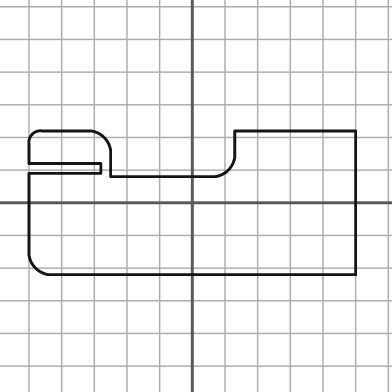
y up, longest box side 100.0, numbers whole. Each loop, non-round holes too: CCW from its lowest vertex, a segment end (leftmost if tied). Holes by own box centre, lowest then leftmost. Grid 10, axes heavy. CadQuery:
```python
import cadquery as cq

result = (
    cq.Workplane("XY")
    .moveTo(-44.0, -22.0)
    .lineTo(50.0, -22.0)
    .lineTo(50.0, 22.0)
    .lineTo(13.0, 22.0)
    .lineTo(13.0, 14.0)
    .threePointArc((11.0, 10.0), (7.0, 8.0))
    .lineTo(-25.0, 8.0)
    .lineTo(-25.0, 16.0)
    .threePointArc((-27.0, 20.0), (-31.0, 22.0))
    .lineTo(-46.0, 22.0)
    .threePointArc((-49.0, 21.0), (-50.0, 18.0))
    .lineTo(-50.0, 12.0)
    .lineTo(-28.0, 12.0)
    .lineTo(-28.0, 9.0)
    .lineTo(-50.0, 9.0)
    .lineTo(-50.0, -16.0)
    .threePointArc((-48.0, -20.0), (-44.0, -22.0))
    .close()
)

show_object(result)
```